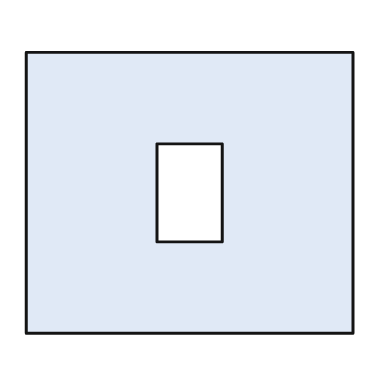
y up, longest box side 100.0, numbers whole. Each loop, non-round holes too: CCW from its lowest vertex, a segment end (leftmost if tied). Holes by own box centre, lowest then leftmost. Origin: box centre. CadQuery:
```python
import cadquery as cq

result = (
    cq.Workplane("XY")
    .moveTo(-50.0, -43.0)
    .lineTo(50.0, -43.0)
    .lineTo(50.0, 43.0)
    .lineTo(-50.0, 43.0)
    .close()
    .moveTo(-10.0, -15.0)
    .lineTo(10.0, -15.0)
    .lineTo(10.0, 15.0)
    .lineTo(-10.0, 15.0)
    .close()
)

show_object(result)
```